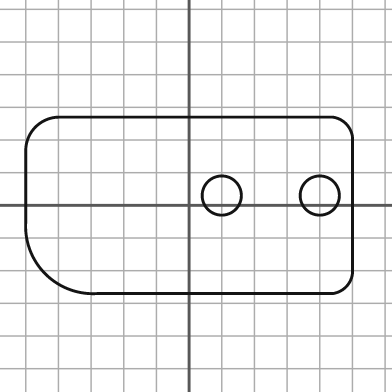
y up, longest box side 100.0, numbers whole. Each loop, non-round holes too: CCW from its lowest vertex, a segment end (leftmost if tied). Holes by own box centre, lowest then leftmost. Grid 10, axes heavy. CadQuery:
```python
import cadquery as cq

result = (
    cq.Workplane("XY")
    .moveTo(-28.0, -27.0)
    .lineTo(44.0, -27.0)
    .threePointArc((48.0, -25.0), (50.0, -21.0))
    .lineTo(50.0, 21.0)
    .threePointArc((48.0, 25.0), (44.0, 27.0))
    .lineTo(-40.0, 27.0)
    .threePointArc((-47.0, 24.0), (-50.0, 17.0))
    .lineTo(-50.0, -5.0)
    .threePointArc((-44.0, -21.0), (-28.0, -27.0))
    .close()
    .moveTo(10.0, 3.0)
    .circle(6.0)
    .moveTo(40.0, 3.0)
    .circle(6.0)
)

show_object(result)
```